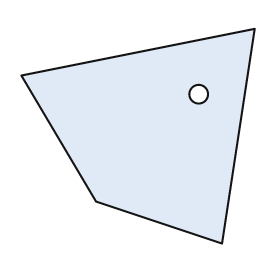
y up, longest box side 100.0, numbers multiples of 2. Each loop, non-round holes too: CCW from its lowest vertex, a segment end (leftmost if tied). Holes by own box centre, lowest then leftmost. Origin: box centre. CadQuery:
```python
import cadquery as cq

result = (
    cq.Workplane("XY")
    .moveTo(36.0, -46.0)
    .lineTo(50.0, 46.0)
    .lineTo(-50.0, 26.0)
    .lineTo(-18.0, -28.0)
    .close()
    .moveTo(26.0, 18.0)
    .circle(4.0)
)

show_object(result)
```